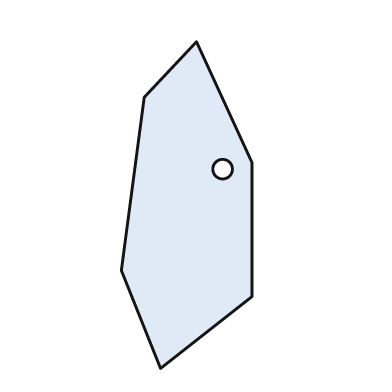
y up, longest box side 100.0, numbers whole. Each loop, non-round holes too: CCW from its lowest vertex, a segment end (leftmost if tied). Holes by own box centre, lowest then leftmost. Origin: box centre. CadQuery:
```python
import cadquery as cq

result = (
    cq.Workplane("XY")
    .moveTo(-8.0, -50.0)
    .lineTo(20.0, -28.0)
    .lineTo(20.0, 13.0)
    .lineTo(3.0, 50.0)
    .lineTo(-13.0, 33.0)
    .lineTo(-20.0, -20.0)
    .close()
    .moveTo(11.0, 11.0)
    .circle(3.0)
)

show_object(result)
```